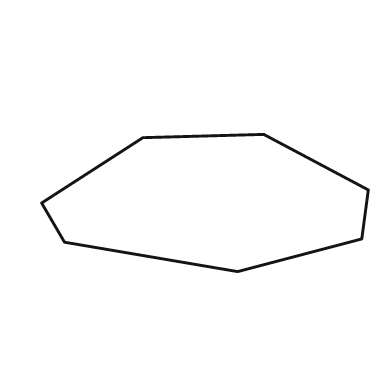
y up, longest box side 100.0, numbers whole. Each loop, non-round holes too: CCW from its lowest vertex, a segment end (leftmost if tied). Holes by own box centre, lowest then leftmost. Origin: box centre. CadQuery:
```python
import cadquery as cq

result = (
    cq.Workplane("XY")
    .moveTo(10.0, -21.0)
    .lineTo(48.0, -11.0)
    .lineTo(50.0, 4.0)
    .lineTo(18.0, 21.0)
    .lineTo(-19.0, 20.0)
    .lineTo(-50.0, 0.0)
    .lineTo(-43.0, -12.0)
    .close()
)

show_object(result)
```